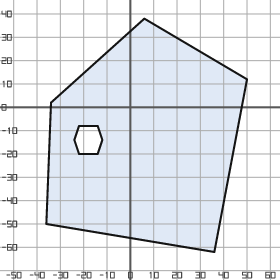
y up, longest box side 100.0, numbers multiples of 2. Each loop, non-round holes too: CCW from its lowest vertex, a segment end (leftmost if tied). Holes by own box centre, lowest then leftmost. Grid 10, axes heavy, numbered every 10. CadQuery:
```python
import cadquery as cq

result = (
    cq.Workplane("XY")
    .moveTo(36.0, -62.0)
    .lineTo(50.0, 12.0)
    .lineTo(6.0, 38.0)
    .lineTo(-34.0, 2.0)
    .lineTo(-36.0, -50.0)
    .close()
    .moveTo(-22.0, -20.0)
    .lineTo(-14.0, -20.0)
    .lineTo(-12.0, -14.0)
    .lineTo(-14.0, -8.0)
    .lineTo(-22.0, -8.0)
    .lineTo(-24.0, -14.0)
    .close()
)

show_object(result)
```